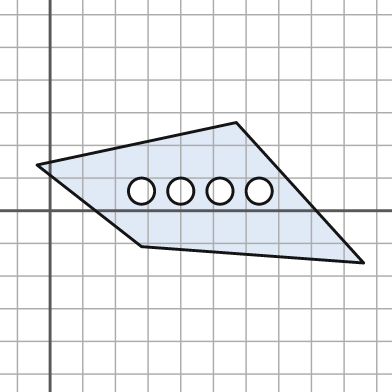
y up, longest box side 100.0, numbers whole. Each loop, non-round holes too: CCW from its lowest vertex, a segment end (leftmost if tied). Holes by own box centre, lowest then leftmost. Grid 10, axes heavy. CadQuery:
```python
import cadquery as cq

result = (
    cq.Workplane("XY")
    .moveTo(96.0, -16.0)
    .lineTo(57.0, 27.0)
    .lineTo(-4.0, 14.0)
    .lineTo(28.0, -11.0)
    .close()
    .moveTo(28.0, 6.0)
    .circle(4.0)
    .moveTo(40.0, 6.0)
    .circle(4.0)
    .moveTo(52.0, 6.0)
    .circle(4.0)
    .moveTo(64.0, 6.0)
    .circle(4.0)
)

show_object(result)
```